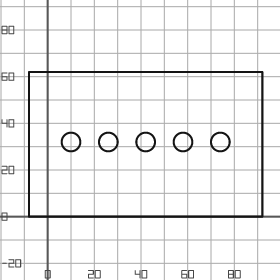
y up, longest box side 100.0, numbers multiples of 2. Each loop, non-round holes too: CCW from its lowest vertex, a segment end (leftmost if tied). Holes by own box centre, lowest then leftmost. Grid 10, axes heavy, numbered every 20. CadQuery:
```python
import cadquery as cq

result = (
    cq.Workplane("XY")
    .moveTo(-8.0, 0.0)
    .lineTo(92.0, 0.0)
    .lineTo(92.0, 62.0)
    .lineTo(-8.0, 62.0)
    .close()
    .moveTo(10.0, 32.0)
    .circle(4.0)
    .moveTo(26.0, 32.0)
    .circle(4.0)
    .moveTo(42.0, 32.0)
    .circle(4.0)
    .moveTo(58.0, 32.0)
    .circle(4.0)
    .moveTo(74.0, 32.0)
    .circle(4.0)
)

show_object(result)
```